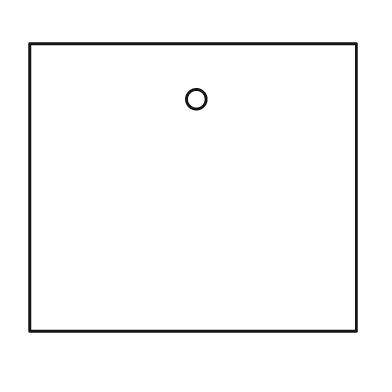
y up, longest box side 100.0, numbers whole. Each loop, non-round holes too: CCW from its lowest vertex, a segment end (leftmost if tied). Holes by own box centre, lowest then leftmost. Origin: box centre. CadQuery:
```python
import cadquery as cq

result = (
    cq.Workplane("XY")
    .moveTo(-50.0, -44.0)
    .lineTo(50.0, -44.0)
    .lineTo(50.0, 44.0)
    .lineTo(-50.0, 44.0)
    .close()
    .moveTo(1.0, 27.0)
    .circle(3.0)
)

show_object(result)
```